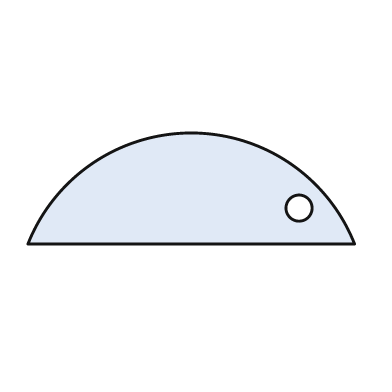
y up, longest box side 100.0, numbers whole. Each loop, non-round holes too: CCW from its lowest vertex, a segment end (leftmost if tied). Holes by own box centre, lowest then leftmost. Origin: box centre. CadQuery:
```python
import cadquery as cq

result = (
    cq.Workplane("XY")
    .moveTo(-50.0, -17.0)
    .lineTo(50.0, -17.0)
    .threePointArc((0.0, 17.0), (-50.0, -17.0))
    .close()
    .moveTo(33.0, -6.0)
    .circle(4.0)
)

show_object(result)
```